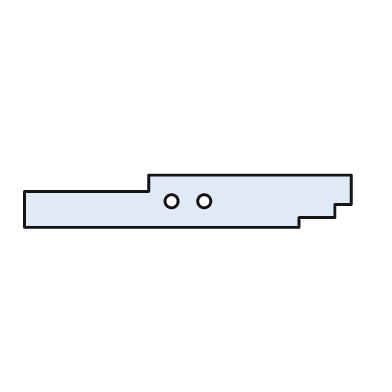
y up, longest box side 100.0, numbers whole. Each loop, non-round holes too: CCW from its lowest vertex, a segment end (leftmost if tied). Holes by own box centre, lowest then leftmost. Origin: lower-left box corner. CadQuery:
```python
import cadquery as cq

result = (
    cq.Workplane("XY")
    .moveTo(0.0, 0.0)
    .lineTo(84.0, 0.0)
    .lineTo(84.0, 3.0)
    .lineTo(95.0, 3.0)
    .lineTo(95.0, 7.0)
    .lineTo(100.0, 7.0)
    .lineTo(100.0, 16.0)
    .lineTo(38.0, 16.0)
    .lineTo(38.0, 11.0)
    .lineTo(0.0, 11.0)
    .close()
    .moveTo(45.0, 8.0)
    .circle(2.0)
    .moveTo(55.0, 8.0)
    .circle(2.0)
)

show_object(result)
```